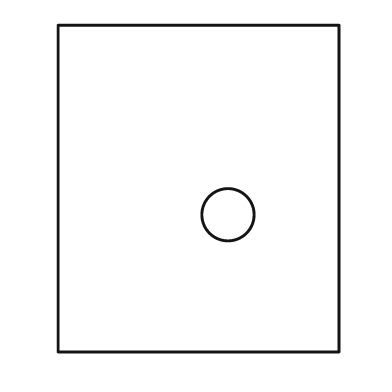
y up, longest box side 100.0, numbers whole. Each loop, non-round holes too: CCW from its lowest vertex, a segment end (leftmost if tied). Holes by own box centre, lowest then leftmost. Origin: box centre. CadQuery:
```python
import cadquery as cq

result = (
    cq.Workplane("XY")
    .moveTo(-43.0, -50.0)
    .lineTo(43.0, -50.0)
    .lineTo(43.0, 50.0)
    .lineTo(-43.0, 50.0)
    .close()
    .moveTo(9.0, -8.0)
    .circle(8.0)
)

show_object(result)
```